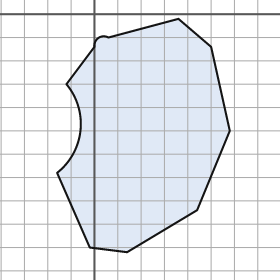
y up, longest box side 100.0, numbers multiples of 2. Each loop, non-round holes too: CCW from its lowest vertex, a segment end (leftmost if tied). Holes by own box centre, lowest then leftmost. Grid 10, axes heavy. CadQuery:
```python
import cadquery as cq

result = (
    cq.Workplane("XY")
    .moveTo(14.0, -102.0)
    .lineTo(44.0, -84.0)
    .lineTo(58.0, -50.0)
    .lineTo(50.0, -14.0)
    .lineTo(36.0, -2.0)
    .lineTo(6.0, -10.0)
    .threePointArc((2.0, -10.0), (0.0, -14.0))
    .lineTo(-12.0, -30.0)
    .threePointArc((-6.0, -50.0), (-16.0, -68.0))
    .lineTo(-2.0, -100.0)
    .close()
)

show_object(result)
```